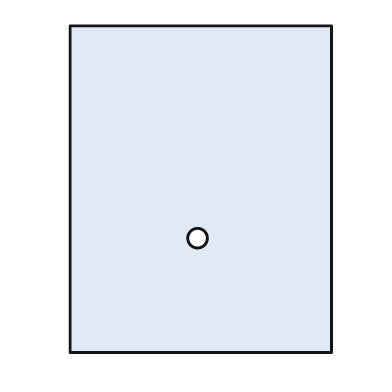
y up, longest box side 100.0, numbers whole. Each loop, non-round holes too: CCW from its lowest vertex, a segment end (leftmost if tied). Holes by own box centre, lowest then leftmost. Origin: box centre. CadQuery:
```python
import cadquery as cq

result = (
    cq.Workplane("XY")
    .moveTo(-40.0, -50.0)
    .lineTo(40.0, -50.0)
    .lineTo(40.0, 50.0)
    .lineTo(-40.0, 50.0)
    .close()
    .moveTo(-1.0, -15.0)
    .circle(3.0)
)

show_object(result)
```